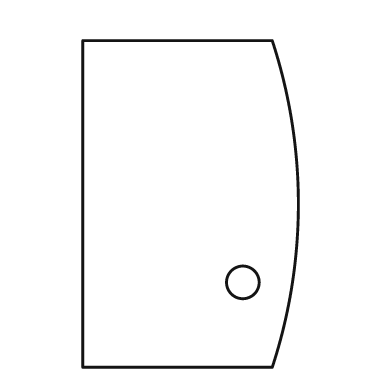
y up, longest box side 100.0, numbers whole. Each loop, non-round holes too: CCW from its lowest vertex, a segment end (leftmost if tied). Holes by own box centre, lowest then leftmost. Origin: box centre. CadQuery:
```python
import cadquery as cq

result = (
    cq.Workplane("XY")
    .moveTo(-33.0, -50.0)
    .lineTo(25.0, -50.0)
    .threePointArc((33.0, 0.0), (25.0, 50.0))
    .lineTo(-33.0, 50.0)
    .close()
    .moveTo(16.0, -24.0)
    .circle(5.0)
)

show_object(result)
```